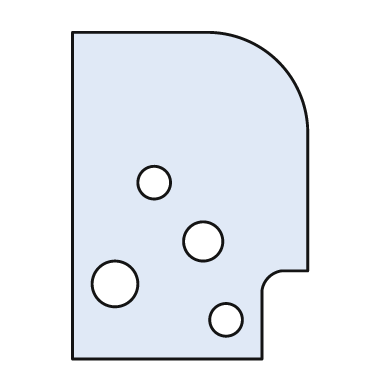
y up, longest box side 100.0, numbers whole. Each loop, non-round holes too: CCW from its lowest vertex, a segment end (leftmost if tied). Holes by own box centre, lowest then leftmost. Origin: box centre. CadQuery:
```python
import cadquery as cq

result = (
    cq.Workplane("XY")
    .moveTo(-36.0, -50.0)
    .lineTo(22.0, -50.0)
    .lineTo(22.0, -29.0)
    .threePointArc((24.0, -25.0), (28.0, -23.0))
    .lineTo(36.0, -23.0)
    .lineTo(36.0, 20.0)
    .threePointArc((27.0, 41.0), (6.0, 50.0))
    .lineTo(-36.0, 50.0)
    .close()
    .moveTo(11.0, -38.0)
    .circle(5.0)
    .moveTo(-23.0, -27.0)
    .circle(7.0)
    .moveTo(4.0, -14.0)
    .circle(6.0)
    .moveTo(-11.0, 4.0)
    .circle(5.0)
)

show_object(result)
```